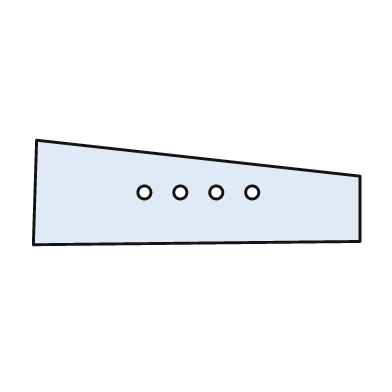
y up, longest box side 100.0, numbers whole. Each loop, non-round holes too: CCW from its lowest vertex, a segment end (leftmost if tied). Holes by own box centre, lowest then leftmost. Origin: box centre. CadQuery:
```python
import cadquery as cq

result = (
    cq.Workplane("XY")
    .moveTo(-50.0, -16.0)
    .lineTo(50.0, -15.0)
    .lineTo(50.0, 5.0)
    .lineTo(-49.0, 16.0)
    .close()
    .moveTo(-16.0, 0.0)
    .circle(2.0)
    .moveTo(-5.0, 0.0)
    .circle(2.0)
    .moveTo(6.0, 0.0)
    .circle(2.0)
    .moveTo(17.0, 0.0)
    .circle(2.0)
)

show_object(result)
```